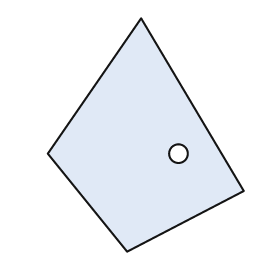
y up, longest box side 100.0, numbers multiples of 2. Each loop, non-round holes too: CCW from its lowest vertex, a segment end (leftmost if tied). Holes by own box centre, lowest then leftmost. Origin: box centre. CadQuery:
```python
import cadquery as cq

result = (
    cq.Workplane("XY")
    .moveTo(-8.0, -50.0)
    .lineTo(42.0, -24.0)
    .lineTo(-2.0, 50.0)
    .lineTo(-42.0, -8.0)
    .close()
    .moveTo(14.0, -8.0)
    .circle(4.0)
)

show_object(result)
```